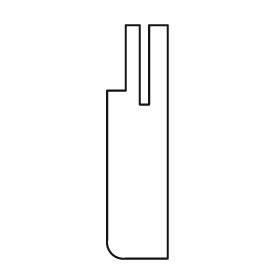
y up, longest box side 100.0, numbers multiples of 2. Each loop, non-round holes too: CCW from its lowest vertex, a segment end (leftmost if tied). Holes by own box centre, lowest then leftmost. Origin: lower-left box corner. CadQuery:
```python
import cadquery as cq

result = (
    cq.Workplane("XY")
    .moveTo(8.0, 0.0)
    .lineTo(26.0, 0.0)
    .lineTo(26.0, 100.0)
    .lineTo(18.0, 100.0)
    .lineTo(18.0, 66.0)
    .lineTo(14.0, 66.0)
    .lineTo(14.0, 100.0)
    .lineTo(8.0, 100.0)
    .lineTo(8.0, 72.0)
    .lineTo(0.0, 72.0)
    .lineTo(0.0, 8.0)
    .threePointArc((2.0, 2.0), (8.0, 0.0))
    .close()
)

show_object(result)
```